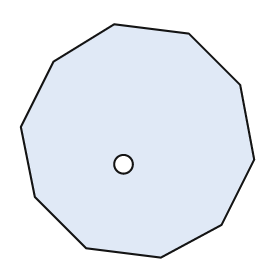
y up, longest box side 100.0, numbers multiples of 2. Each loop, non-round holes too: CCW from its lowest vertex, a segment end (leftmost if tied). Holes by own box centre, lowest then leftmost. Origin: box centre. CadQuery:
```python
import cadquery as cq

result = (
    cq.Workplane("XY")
    .moveTo(10.0, -50.0)
    .lineTo(36.0, -36.0)
    .lineTo(50.0, -8.0)
    .lineTo(44.0, 24.0)
    .lineTo(22.0, 46.0)
    .lineTo(-10.0, 50.0)
    .lineTo(-36.0, 34.0)
    .lineTo(-50.0, 6.0)
    .lineTo(-44.0, -24.0)
    .lineTo(-22.0, -46.0)
    .close()
    .moveTo(-6.0, -10.0)
    .circle(4.0)
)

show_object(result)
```